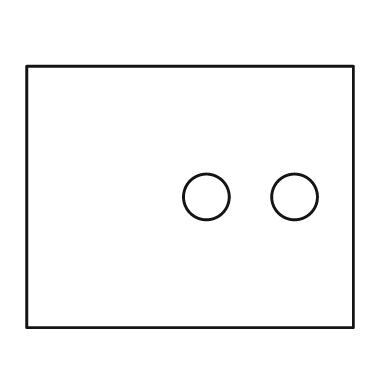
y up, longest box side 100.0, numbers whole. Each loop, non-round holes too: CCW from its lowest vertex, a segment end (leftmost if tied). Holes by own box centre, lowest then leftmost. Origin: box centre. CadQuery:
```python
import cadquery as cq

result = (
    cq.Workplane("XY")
    .moveTo(-50.0, -40.0)
    .lineTo(50.0, -40.0)
    .lineTo(50.0, 40.0)
    .lineTo(-50.0, 40.0)
    .close()
    .moveTo(5.0, 0.0)
    .circle(7.0)
    .moveTo(32.0, 0.0)
    .circle(7.0)
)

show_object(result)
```